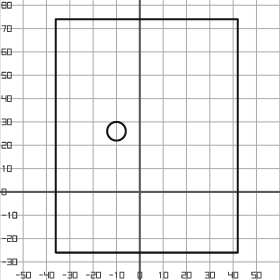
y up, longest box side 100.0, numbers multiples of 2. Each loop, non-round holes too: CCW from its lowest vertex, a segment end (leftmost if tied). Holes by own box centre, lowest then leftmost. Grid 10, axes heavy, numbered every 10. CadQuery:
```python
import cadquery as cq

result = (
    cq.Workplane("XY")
    .moveTo(-36.0, -26.0)
    .lineTo(42.0, -26.0)
    .lineTo(42.0, 74.0)
    .lineTo(-36.0, 74.0)
    .close()
    .moveTo(-10.0, 26.0)
    .circle(4.0)
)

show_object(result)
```